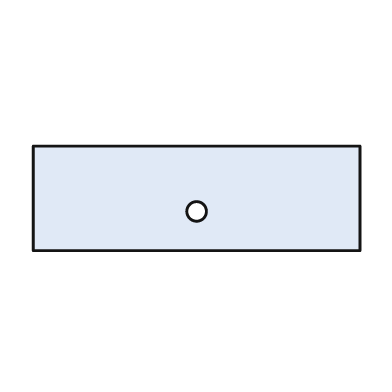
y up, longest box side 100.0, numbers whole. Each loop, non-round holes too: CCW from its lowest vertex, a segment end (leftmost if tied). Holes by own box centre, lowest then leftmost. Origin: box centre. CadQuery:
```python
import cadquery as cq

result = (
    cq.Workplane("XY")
    .moveTo(-50.0, -16.0)
    .lineTo(50.0, -16.0)
    .lineTo(50.0, 16.0)
    .lineTo(-50.0, 16.0)
    .close()
    .moveTo(0.0, -4.0)
    .circle(3.0)
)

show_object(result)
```